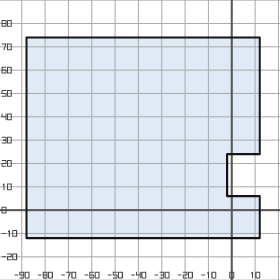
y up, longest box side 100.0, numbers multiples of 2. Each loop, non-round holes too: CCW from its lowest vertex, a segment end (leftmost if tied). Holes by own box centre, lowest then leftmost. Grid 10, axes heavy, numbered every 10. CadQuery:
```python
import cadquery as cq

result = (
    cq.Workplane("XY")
    .moveTo(-88.0, -12.0)
    .lineTo(12.0, -12.0)
    .lineTo(12.0, 6.0)
    .lineTo(-2.0, 6.0)
    .lineTo(-2.0, 24.0)
    .lineTo(12.0, 24.0)
    .lineTo(12.0, 74.0)
    .lineTo(-88.0, 74.0)
    .close()
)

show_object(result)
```